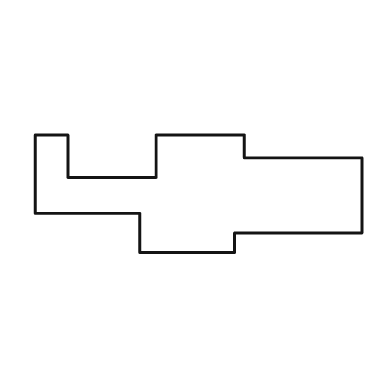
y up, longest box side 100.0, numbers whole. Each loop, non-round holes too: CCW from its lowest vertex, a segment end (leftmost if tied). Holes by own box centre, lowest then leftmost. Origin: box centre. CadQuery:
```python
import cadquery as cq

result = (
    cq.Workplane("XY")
    .moveTo(-18.0, -18.0)
    .lineTo(11.0, -18.0)
    .lineTo(11.0, -12.0)
    .lineTo(50.0, -12.0)
    .lineTo(50.0, 11.0)
    .lineTo(14.0, 11.0)
    .lineTo(14.0, 18.0)
    .lineTo(-13.0, 18.0)
    .lineTo(-13.0, 5.0)
    .lineTo(-40.0, 5.0)
    .lineTo(-40.0, 18.0)
    .lineTo(-50.0, 18.0)
    .lineTo(-50.0, -6.0)
    .lineTo(-18.0, -6.0)
    .close()
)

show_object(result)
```